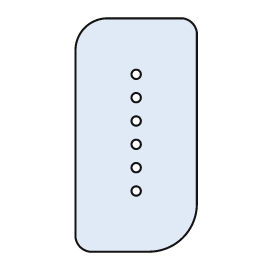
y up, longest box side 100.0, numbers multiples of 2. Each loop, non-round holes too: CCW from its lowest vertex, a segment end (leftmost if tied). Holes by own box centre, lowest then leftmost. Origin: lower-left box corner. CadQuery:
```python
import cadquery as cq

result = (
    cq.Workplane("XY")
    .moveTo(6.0, 0.0)
    .lineTo(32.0, 0.0)
    .threePointArc((46.0, 6.0), (52.0, 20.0))
    .lineTo(52.0, 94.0)
    .threePointArc((50.0, 98.0), (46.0, 100.0))
    .lineTo(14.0, 100.0)
    .threePointArc((4.0, 96.0), (0.0, 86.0))
    .lineTo(0.0, 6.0)
    .threePointArc((2.0, 2.0), (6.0, 0.0))
    .close()
    .moveTo(26.0, 26.0)
    .circle(2.0)
    .moveTo(26.0, 36.0)
    .circle(2.0)
    .moveTo(26.0, 46.0)
    .circle(2.0)
    .moveTo(26.0, 56.0)
    .circle(2.0)
    .moveTo(26.0, 66.0)
    .circle(2.0)
    .moveTo(26.0, 76.0)
    .circle(2.0)
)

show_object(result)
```